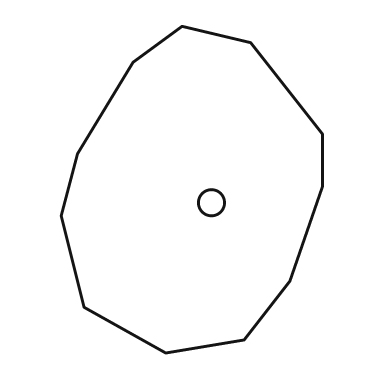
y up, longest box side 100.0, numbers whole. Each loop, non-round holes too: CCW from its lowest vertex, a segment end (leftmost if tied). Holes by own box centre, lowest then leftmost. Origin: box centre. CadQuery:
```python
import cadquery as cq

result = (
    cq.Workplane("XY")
    .moveTo(-8.0, -50.0)
    .lineTo(16.0, -46.0)
    .lineTo(30.0, -28.0)
    .lineTo(40.0, 1.0)
    .lineTo(40.0, 17.0)
    .lineTo(18.0, 45.0)
    .lineTo(-3.0, 50.0)
    .lineTo(-18.0, 39.0)
    .lineTo(-35.0, 11.0)
    .lineTo(-40.0, -8.0)
    .lineTo(-33.0, -36.0)
    .close()
    .moveTo(6.0, -4.0)
    .circle(4.0)
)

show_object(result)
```